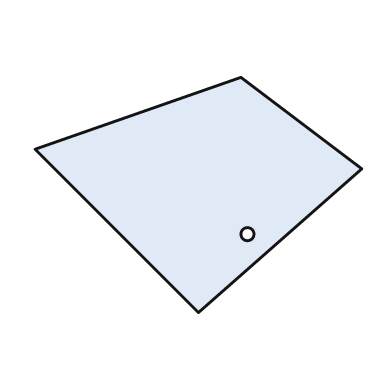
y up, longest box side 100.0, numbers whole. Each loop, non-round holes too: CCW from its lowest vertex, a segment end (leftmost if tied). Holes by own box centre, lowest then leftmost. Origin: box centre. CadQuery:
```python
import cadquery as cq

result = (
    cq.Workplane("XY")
    .moveTo(0.0, -36.0)
    .lineTo(50.0, 8.0)
    .lineTo(13.0, 36.0)
    .lineTo(-50.0, 14.0)
    .close()
    .moveTo(15.0, -12.0)
    .circle(2.0)
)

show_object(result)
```